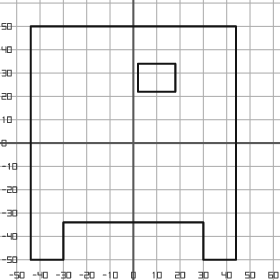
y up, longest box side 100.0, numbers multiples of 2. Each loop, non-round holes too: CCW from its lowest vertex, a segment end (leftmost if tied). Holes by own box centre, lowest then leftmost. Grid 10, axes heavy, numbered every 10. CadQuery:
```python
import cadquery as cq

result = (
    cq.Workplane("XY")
    .moveTo(-44.0, -50.0)
    .lineTo(-30.0, -50.0)
    .lineTo(-30.0, -34.0)
    .lineTo(30.0, -34.0)
    .lineTo(30.0, -50.0)
    .lineTo(44.0, -50.0)
    .lineTo(44.0, 50.0)
    .lineTo(-44.0, 50.0)
    .close()
    .moveTo(2.0, 22.0)
    .lineTo(18.0, 22.0)
    .lineTo(18.0, 34.0)
    .lineTo(2.0, 34.0)
    .close()
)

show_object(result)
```